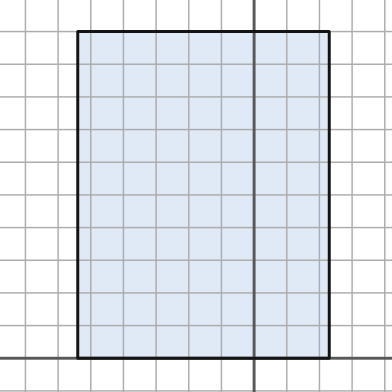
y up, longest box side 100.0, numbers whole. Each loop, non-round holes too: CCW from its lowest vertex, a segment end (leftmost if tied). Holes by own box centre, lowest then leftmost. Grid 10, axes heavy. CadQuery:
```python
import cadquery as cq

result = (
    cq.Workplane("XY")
    .moveTo(-54.0, 0.0)
    .lineTo(23.0, 0.0)
    .lineTo(23.0, 100.0)
    .lineTo(-54.0, 100.0)
    .close()
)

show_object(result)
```